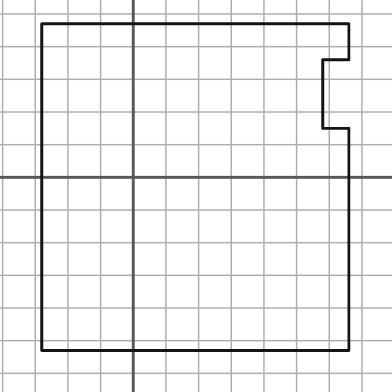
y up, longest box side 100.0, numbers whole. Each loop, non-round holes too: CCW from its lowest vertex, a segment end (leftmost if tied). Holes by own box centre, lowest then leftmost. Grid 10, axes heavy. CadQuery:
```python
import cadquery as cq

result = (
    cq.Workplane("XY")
    .moveTo(-28.0, -53.0)
    .lineTo(66.0, -53.0)
    .lineTo(66.0, 15.0)
    .lineTo(58.0, 15.0)
    .lineTo(58.0, 36.0)
    .lineTo(66.0, 36.0)
    .lineTo(66.0, 47.0)
    .lineTo(-28.0, 47.0)
    .close()
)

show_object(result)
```